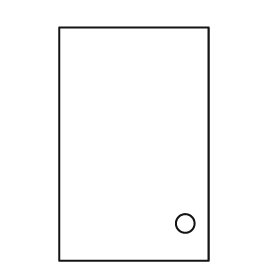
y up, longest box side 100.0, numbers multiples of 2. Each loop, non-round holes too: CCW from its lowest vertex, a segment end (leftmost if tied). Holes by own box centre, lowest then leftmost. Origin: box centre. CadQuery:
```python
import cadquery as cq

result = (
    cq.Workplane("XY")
    .moveTo(-32.0, -50.0)
    .lineTo(32.0, -50.0)
    .lineTo(32.0, 50.0)
    .lineTo(-32.0, 50.0)
    .close()
    .moveTo(22.0, -34.0)
    .circle(4.0)
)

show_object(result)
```